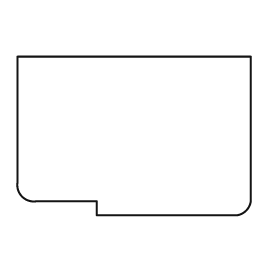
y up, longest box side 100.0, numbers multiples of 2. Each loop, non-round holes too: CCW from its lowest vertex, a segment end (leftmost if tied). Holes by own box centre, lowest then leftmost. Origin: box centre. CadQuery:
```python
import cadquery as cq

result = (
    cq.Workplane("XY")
    .moveTo(-16.0, -34.0)
    .lineTo(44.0, -34.0)
    .threePointArc((48.0, -32.0), (50.0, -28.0))
    .lineTo(50.0, 34.0)
    .lineTo(-50.0, 34.0)
    .lineTo(-50.0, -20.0)
    .threePointArc((-48.0, -26.0), (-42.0, -28.0))
    .lineTo(-16.0, -28.0)
    .close()
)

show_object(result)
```